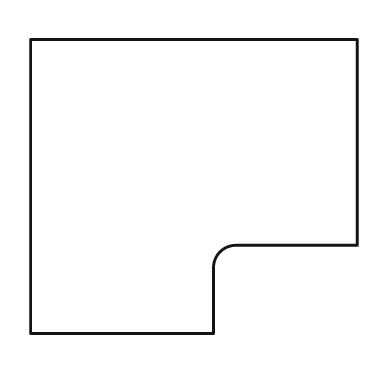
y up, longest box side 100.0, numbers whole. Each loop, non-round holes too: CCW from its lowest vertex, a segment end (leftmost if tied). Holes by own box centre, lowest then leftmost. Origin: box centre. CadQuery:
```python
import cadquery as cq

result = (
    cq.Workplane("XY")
    .moveTo(-50.0, -45.0)
    .lineTo(6.0, -45.0)
    .lineTo(6.0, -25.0)
    .threePointArc((8.0, -20.0), (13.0, -18.0))
    .lineTo(50.0, -18.0)
    .lineTo(50.0, 45.0)
    .lineTo(-50.0, 45.0)
    .close()
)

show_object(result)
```